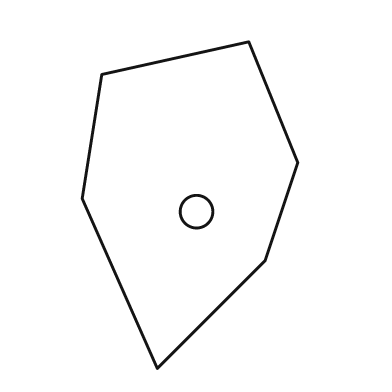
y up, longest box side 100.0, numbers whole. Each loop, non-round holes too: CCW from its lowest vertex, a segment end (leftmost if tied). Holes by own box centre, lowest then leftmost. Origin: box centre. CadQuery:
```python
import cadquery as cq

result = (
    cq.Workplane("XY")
    .moveTo(-10.0, -50.0)
    .lineTo(23.0, -17.0)
    .lineTo(33.0, 13.0)
    .lineTo(18.0, 50.0)
    .lineTo(-27.0, 40.0)
    .lineTo(-33.0, 2.0)
    .close()
    .moveTo(2.0, -2.0)
    .circle(5.0)
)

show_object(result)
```